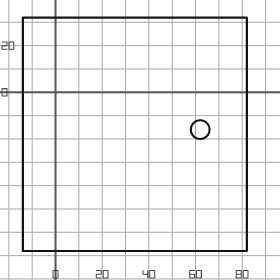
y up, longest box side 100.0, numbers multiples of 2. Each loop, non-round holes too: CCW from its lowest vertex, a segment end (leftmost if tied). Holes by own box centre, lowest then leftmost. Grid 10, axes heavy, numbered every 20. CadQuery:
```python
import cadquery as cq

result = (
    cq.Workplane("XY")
    .moveTo(-14.0, -68.0)
    .lineTo(82.0, -68.0)
    .lineTo(82.0, 32.0)
    .lineTo(-14.0, 32.0)
    .close()
    .moveTo(62.0, -16.0)
    .circle(4.0)
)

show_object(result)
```